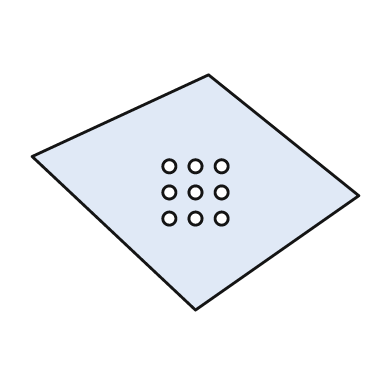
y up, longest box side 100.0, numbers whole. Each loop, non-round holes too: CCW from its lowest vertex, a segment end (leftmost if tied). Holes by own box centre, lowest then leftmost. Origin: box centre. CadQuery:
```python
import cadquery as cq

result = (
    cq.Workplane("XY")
    .moveTo(0.0, -36.0)
    .lineTo(50.0, -1.0)
    .lineTo(4.0, 36.0)
    .lineTo(-50.0, 11.0)
    .close()
    .moveTo(-8.0, -8.0)
    .circle(2.0)
    .moveTo(0.0, -8.0)
    .circle(2.0)
    .moveTo(8.0, -8.0)
    .circle(2.0)
    .moveTo(-8.0, 0.0)
    .circle(2.0)
    .moveTo(0.0, 0.0)
    .circle(2.0)
    .moveTo(8.0, 0.0)
    .circle(2.0)
    .moveTo(-8.0, 8.0)
    .circle(2.0)
    .moveTo(0.0, 8.0)
    .circle(2.0)
    .moveTo(8.0, 8.0)
    .circle(2.0)
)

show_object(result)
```